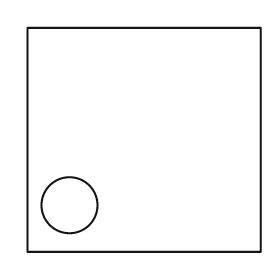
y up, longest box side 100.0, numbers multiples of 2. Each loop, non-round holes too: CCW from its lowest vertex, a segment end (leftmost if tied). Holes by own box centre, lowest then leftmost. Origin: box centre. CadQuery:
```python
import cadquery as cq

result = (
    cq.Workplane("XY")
    .moveTo(-50.0, -48.0)
    .lineTo(50.0, -48.0)
    .lineTo(50.0, 48.0)
    .lineTo(-50.0, 48.0)
    .close()
    .moveTo(-32.0, -28.0)
    .circle(12.0)
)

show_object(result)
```